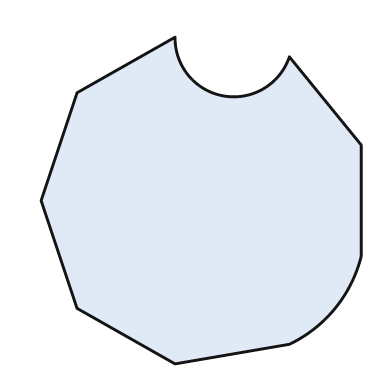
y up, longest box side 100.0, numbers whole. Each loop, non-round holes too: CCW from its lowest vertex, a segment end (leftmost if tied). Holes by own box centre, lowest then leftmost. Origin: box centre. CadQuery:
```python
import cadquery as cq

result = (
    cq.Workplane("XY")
    .moveTo(-8.0, -50.0)
    .lineTo(27.0, -44.0)
    .threePointArc((41.0, -33.0), (49.0, -17.0))
    .lineTo(49.0, 17.0)
    .lineTo(27.0, 44.0)
    .threePointArc((7.0, 32.0), (-8.0, 50.0))
    .lineTo(-38.0, 33.0)
    .lineTo(-49.0, 0.0)
    .lineTo(-38.0, -33.0)
    .close()
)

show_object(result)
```